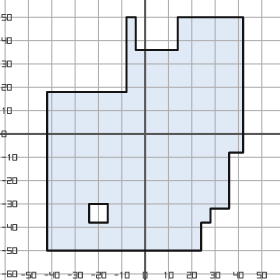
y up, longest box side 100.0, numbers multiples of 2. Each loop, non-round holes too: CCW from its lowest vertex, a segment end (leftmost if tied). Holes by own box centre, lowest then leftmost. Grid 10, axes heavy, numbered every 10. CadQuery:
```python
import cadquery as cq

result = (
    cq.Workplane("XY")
    .moveTo(-42.0, -50.0)
    .lineTo(24.0, -50.0)
    .lineTo(24.0, -38.0)
    .lineTo(28.0, -38.0)
    .lineTo(28.0, -32.0)
    .lineTo(36.0, -32.0)
    .lineTo(36.0, -8.0)
    .lineTo(42.0, -8.0)
    .lineTo(42.0, 50.0)
    .lineTo(14.0, 50.0)
    .lineTo(14.0, 36.0)
    .lineTo(-4.0, 36.0)
    .lineTo(-4.0, 50.0)
    .lineTo(-8.0, 50.0)
    .lineTo(-8.0, 18.0)
    .lineTo(-42.0, 18.0)
    .close()
    .moveTo(-24.0, -38.0)
    .lineTo(-16.0, -38.0)
    .lineTo(-16.0, -30.0)
    .lineTo(-24.0, -30.0)
    .close()
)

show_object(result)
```